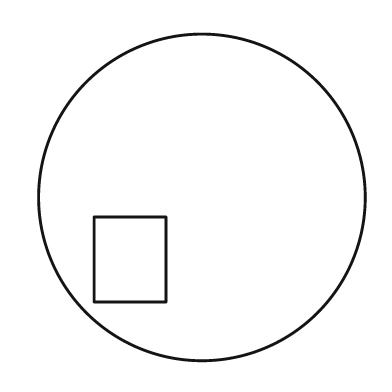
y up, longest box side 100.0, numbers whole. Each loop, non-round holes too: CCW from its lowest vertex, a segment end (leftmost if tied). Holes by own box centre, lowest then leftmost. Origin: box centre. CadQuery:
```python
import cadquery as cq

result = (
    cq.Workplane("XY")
    .moveTo(0.0, 0.0)
    .circle(50.0)
    .moveTo(-33.0, -32.0)
    .lineTo(-11.0, -32.0)
    .lineTo(-11.0, -6.0)
    .lineTo(-33.0, -6.0)
    .close()
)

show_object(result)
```